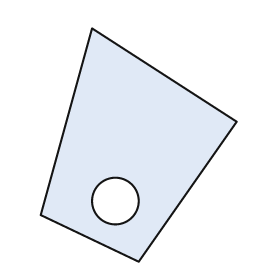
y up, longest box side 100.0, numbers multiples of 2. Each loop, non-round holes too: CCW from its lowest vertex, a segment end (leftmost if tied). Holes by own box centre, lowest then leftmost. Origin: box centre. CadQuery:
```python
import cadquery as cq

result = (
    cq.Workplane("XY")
    .moveTo(0.0, -50.0)
    .lineTo(42.0, 10.0)
    .lineTo(-20.0, 50.0)
    .lineTo(-42.0, -30.0)
    .close()
    .moveTo(-10.0, -24.0)
    .circle(10.0)
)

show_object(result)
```